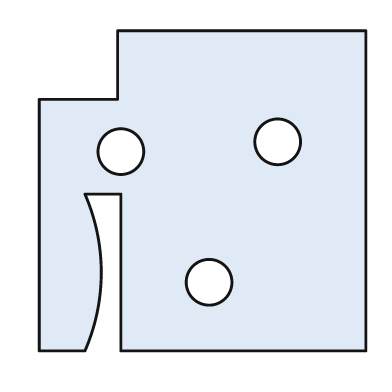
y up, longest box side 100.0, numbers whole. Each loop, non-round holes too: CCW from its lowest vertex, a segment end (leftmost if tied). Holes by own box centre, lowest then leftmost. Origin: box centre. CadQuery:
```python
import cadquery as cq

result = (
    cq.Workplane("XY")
    .moveTo(-50.0, -49.0)
    .lineTo(-36.0, -49.0)
    .threePointArc((-31.0, -25.0), (-36.0, -1.0))
    .lineTo(-25.0, -1.0)
    .lineTo(-25.0, -49.0)
    .lineTo(50.0, -49.0)
    .lineTo(50.0, 49.0)
    .lineTo(-26.0, 49.0)
    .lineTo(-26.0, 28.0)
    .lineTo(-50.0, 28.0)
    .close()
    .moveTo(2.0, -28.0)
    .circle(7.0)
    .moveTo(-25.0, 12.0)
    .circle(7.0)
    .moveTo(23.0, 15.0)
    .circle(7.0)
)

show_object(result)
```